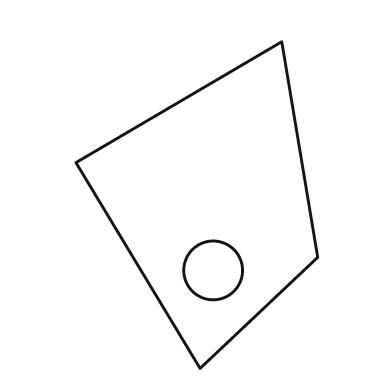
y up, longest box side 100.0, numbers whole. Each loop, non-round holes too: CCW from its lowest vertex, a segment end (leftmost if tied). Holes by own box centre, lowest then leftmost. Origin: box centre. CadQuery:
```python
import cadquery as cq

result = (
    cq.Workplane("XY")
    .moveTo(1.0, -50.0)
    .lineTo(37.0, -16.0)
    .lineTo(26.0, 50.0)
    .lineTo(-37.0, 13.0)
    .close()
    .moveTo(5.0, -20.0)
    .circle(9.0)
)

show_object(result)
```